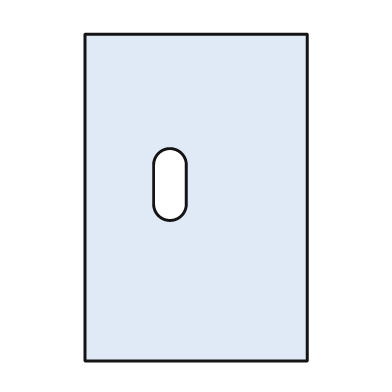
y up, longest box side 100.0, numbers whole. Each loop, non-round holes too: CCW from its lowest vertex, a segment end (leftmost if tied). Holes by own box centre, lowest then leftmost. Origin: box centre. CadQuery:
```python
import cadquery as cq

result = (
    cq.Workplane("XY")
    .moveTo(-34.0, -50.0)
    .lineTo(34.0, -50.0)
    .lineTo(34.0, 50.0)
    .lineTo(-34.0, 50.0)
    .close()
    .moveTo(-13.0, -2.0)
    .threePointArc((-8.0, -7.0), (-3.0, -2.0))
    .lineTo(-3.0, 10.0)
    .threePointArc((-8.0, 15.0), (-13.0, 10.0))
    .close()
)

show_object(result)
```